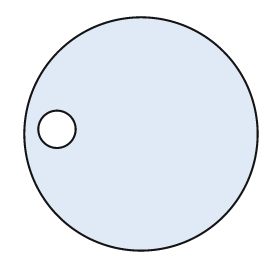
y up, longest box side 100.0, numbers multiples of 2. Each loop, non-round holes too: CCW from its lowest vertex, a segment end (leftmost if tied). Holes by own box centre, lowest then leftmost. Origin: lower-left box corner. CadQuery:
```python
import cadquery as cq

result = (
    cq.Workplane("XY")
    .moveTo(50.0, 50.0)
    .circle(50.0)
    .moveTo(14.0, 52.0)
    .circle(8.0)
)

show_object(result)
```